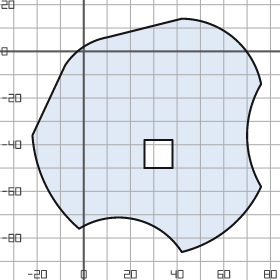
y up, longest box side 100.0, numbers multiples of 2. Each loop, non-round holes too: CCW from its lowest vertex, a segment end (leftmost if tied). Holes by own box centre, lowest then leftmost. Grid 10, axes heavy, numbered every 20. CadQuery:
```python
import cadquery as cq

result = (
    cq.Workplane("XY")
    .moveTo(42.0, -86.0)
    .threePointArc((62.0, -76.0), (76.0, -58.0))
    .threePointArc((70.0, -36.0), (76.0, -14.0))
    .threePointArc((64.0, 6.0), (42.0, 14.0))
    .lineTo(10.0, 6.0)
    .threePointArc((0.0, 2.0), (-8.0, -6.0))
    .lineTo(-22.0, -36.0)
    .threePointArc((-16.0, -58.0), (-2.0, -76.0))
    .threePointArc((22.0, -72.0), (42.0, -86.0))
    .close()
    .moveTo(26.0, -50.0)
    .lineTo(38.0, -50.0)
    .lineTo(38.0, -38.0)
    .lineTo(26.0, -38.0)
    .close()
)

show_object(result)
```